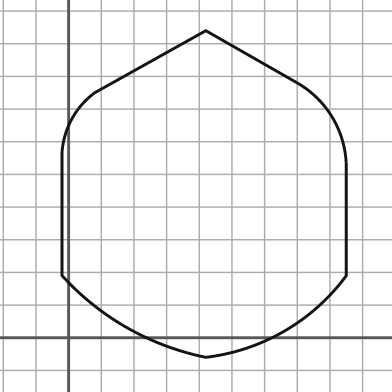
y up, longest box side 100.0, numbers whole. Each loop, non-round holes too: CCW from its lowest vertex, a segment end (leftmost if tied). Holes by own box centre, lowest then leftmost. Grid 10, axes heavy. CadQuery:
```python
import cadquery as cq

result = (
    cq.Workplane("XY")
    .moveTo(42.0, -6.0)
    .threePointArc((66.0, 2.0), (85.0, 19.0))
    .lineTo(85.0, 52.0)
    .threePointArc((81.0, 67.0), (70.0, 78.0))
    .lineTo(42.0, 94.0)
    .lineTo(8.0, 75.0)
    .threePointArc((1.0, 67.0), (-2.0, 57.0))
    .lineTo(-2.0, 19.0)
    .threePointArc((18.0, 3.0), (42.0, -6.0))
    .close()
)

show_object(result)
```